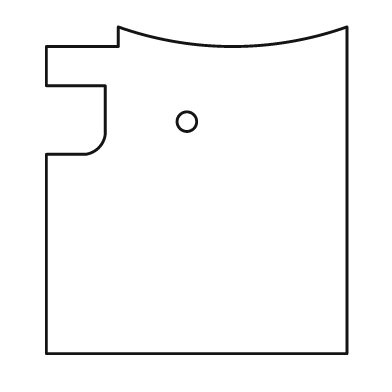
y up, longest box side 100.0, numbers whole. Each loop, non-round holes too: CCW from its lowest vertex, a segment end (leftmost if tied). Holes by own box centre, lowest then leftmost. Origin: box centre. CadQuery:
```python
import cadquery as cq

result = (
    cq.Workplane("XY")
    .moveTo(-46.0, -50.0)
    .lineTo(46.0, -50.0)
    .lineTo(46.0, 50.0)
    .threePointArc((11.0, 44.0), (-24.0, 50.0))
    .lineTo(-24.0, 44.0)
    .lineTo(-46.0, 44.0)
    .lineTo(-46.0, 32.0)
    .lineTo(-28.0, 32.0)
    .lineTo(-28.0, 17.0)
    .threePointArc((-30.0, 13.0), (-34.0, 11.0))
    .lineTo(-46.0, 11.0)
    .close()
    .moveTo(-3.0, 21.0)
    .circle(3.0)
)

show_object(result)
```